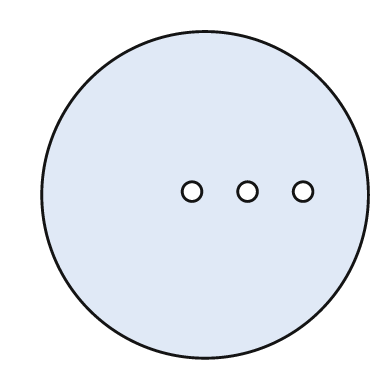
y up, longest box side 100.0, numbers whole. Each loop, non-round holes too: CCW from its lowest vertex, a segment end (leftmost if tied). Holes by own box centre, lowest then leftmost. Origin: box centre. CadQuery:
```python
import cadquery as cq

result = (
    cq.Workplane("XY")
    .moveTo(0.0, 0.0)
    .circle(50.0)
    .moveTo(-4.0, 1.0)
    .circle(3.0)
    .moveTo(13.0, 1.0)
    .circle(3.0)
    .moveTo(30.0, 1.0)
    .circle(3.0)
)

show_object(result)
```